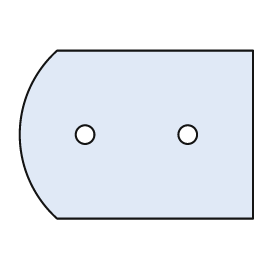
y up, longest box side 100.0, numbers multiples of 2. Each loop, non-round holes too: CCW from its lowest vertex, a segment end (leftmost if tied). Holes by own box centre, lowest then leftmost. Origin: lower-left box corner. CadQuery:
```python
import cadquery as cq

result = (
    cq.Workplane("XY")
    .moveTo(16.0, 0.0)
    .lineTo(100.0, 0.0)
    .lineTo(100.0, 72.0)
    .lineTo(16.0, 72.0)
    .threePointArc((0.0, 36.0), (16.0, 0.0))
    .close()
    .moveTo(28.0, 36.0)
    .circle(4.0)
    .moveTo(72.0, 36.0)
    .circle(4.0)
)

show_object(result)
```